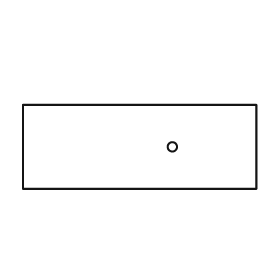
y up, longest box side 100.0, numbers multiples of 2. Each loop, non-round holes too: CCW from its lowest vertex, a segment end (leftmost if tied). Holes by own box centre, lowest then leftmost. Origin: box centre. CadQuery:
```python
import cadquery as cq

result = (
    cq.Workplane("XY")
    .moveTo(-50.0, -18.0)
    .lineTo(50.0, -18.0)
    .lineTo(50.0, 18.0)
    .lineTo(-50.0, 18.0)
    .close()
    .moveTo(14.0, 0.0)
    .circle(2.0)
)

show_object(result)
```